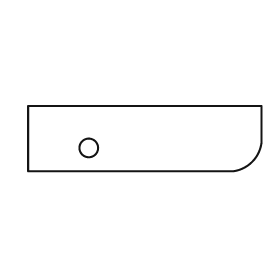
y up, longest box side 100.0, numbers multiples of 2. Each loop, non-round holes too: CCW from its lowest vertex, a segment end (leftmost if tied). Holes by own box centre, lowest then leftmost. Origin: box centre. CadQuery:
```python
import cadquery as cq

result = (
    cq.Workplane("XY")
    .moveTo(-50.0, -14.0)
    .lineTo(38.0, -14.0)
    .threePointArc((46.0, -10.0), (50.0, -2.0))
    .lineTo(50.0, 14.0)
    .lineTo(-50.0, 14.0)
    .close()
    .moveTo(-24.0, -4.0)
    .circle(4.0)
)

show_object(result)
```